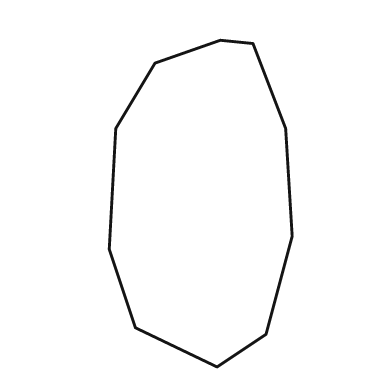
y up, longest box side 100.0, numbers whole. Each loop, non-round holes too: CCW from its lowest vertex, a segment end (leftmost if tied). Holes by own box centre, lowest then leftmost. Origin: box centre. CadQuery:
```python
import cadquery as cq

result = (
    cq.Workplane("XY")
    .moveTo(5.0, -50.0)
    .lineTo(20.0, -40.0)
    .lineTo(28.0, -10.0)
    .lineTo(26.0, 23.0)
    .lineTo(16.0, 49.0)
    .lineTo(6.0, 50.0)
    .lineTo(-14.0, 43.0)
    .lineTo(-26.0, 23.0)
    .lineTo(-28.0, -14.0)
    .lineTo(-20.0, -38.0)
    .close()
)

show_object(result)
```